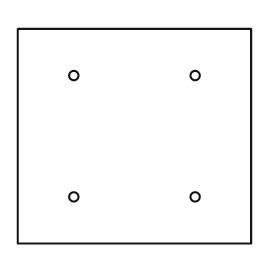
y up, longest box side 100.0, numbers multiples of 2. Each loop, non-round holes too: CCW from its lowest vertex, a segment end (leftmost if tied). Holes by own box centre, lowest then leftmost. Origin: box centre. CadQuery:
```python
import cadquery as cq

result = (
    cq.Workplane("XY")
    .moveTo(-50.0, -46.0)
    .lineTo(50.0, -46.0)
    .lineTo(50.0, 46.0)
    .lineTo(-50.0, 46.0)
    .close()
    .moveTo(-26.0, -26.0)
    .circle(2.0)
    .moveTo(26.0, -26.0)
    .circle(2.0)
    .moveTo(-26.0, 26.0)
    .circle(2.0)
    .moveTo(26.0, 26.0)
    .circle(2.0)
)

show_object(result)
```